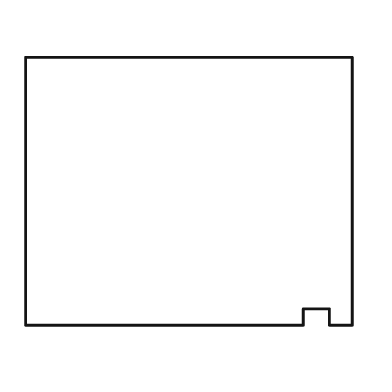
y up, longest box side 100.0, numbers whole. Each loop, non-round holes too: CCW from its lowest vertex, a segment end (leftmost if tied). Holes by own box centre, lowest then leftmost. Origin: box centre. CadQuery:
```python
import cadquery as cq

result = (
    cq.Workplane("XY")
    .moveTo(-50.0, -41.0)
    .lineTo(35.0, -41.0)
    .lineTo(35.0, -36.0)
    .lineTo(43.0, -36.0)
    .lineTo(43.0, -41.0)
    .lineTo(50.0, -41.0)
    .lineTo(50.0, 41.0)
    .lineTo(-50.0, 41.0)
    .close()
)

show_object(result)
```